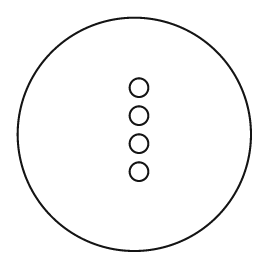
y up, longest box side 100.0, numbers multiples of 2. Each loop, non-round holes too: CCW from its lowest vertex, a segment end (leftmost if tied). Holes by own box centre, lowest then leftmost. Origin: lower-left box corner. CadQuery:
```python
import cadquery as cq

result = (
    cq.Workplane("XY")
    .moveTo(50.0, 50.0)
    .circle(50.0)
    .moveTo(52.0, 34.0)
    .circle(4.0)
    .moveTo(52.0, 46.0)
    .circle(4.0)
    .moveTo(52.0, 58.0)
    .circle(4.0)
    .moveTo(52.0, 70.0)
    .circle(4.0)
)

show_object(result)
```